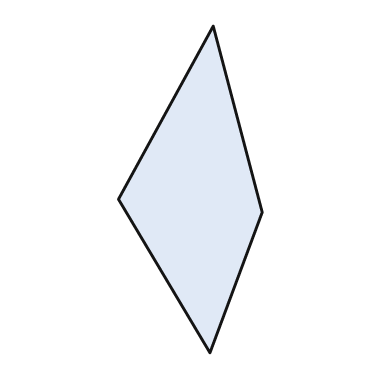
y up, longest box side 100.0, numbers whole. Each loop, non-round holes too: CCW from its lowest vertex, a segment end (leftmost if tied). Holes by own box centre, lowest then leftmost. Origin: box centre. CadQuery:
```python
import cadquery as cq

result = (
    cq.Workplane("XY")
    .moveTo(6.0, -50.0)
    .lineTo(22.0, -7.0)
    .lineTo(7.0, 50.0)
    .lineTo(-22.0, -3.0)
    .close()
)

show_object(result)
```